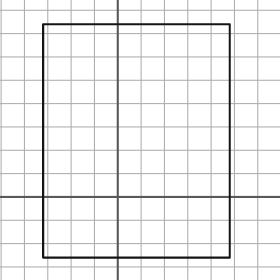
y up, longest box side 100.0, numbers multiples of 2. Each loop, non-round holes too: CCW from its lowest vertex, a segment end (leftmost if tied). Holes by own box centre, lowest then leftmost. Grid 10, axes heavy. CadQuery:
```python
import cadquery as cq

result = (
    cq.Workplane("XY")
    .moveTo(-32.0, -26.0)
    .lineTo(48.0, -26.0)
    .lineTo(48.0, 74.0)
    .lineTo(-32.0, 74.0)
    .close()
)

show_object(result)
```